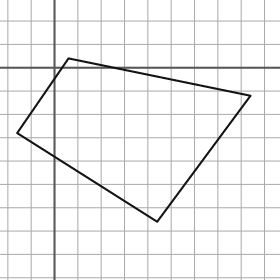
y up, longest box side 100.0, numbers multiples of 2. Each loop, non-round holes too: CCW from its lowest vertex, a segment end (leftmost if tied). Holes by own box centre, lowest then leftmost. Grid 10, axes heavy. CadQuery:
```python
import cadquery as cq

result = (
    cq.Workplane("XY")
    .moveTo(44.0, -66.0)
    .lineTo(84.0, -12.0)
    .lineTo(6.0, 4.0)
    .lineTo(-16.0, -28.0)
    .close()
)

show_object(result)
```